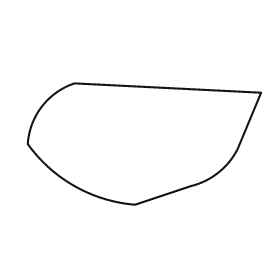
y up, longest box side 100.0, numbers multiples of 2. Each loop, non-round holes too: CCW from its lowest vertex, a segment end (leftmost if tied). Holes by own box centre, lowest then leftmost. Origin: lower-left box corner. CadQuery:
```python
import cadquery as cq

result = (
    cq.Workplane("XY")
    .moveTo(46.0, 0.0)
    .lineTo(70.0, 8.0)
    .threePointArc((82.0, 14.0), (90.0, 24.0))
    .lineTo(100.0, 48.0)
    .lineTo(20.0, 52.0)
    .threePointArc((6.0, 42.0), (0.0, 26.0))
    .threePointArc((20.0, 8.0), (46.0, 0.0))
    .close()
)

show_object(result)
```